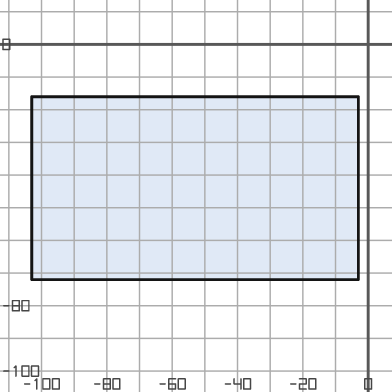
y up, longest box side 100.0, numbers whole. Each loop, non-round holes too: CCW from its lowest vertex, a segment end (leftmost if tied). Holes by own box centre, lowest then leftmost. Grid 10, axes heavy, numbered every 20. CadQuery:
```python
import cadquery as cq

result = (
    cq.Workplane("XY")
    .moveTo(-103.0, -72.0)
    .lineTo(-3.0, -72.0)
    .lineTo(-3.0, -16.0)
    .lineTo(-103.0, -16.0)
    .close()
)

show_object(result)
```